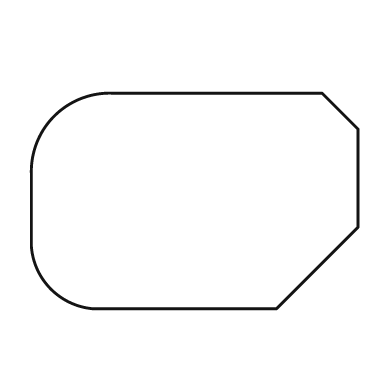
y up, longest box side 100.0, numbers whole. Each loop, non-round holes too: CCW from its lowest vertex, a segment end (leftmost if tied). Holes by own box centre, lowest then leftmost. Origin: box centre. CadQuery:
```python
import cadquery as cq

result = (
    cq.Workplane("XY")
    .moveTo(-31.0, -33.0)
    .lineTo(25.0, -33.0)
    .lineTo(50.0, -8.0)
    .lineTo(50.0, 22.0)
    .lineTo(39.0, 33.0)
    .lineTo(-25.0, 33.0)
    .threePointArc((-43.0, 26.0), (-50.0, 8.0))
    .lineTo(-50.0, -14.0)
    .threePointArc((-44.0, -27.0), (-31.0, -33.0))
    .close()
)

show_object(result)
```